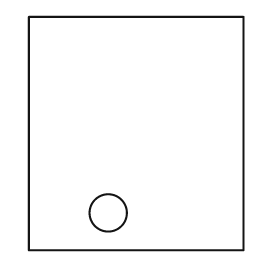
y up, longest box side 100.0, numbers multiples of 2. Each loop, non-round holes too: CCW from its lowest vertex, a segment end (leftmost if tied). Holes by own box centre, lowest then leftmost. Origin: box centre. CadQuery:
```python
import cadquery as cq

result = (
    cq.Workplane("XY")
    .moveTo(-46.0, -50.0)
    .lineTo(46.0, -50.0)
    .lineTo(46.0, 50.0)
    .lineTo(-46.0, 50.0)
    .close()
    .moveTo(-12.0, -34.0)
    .circle(8.0)
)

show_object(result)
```